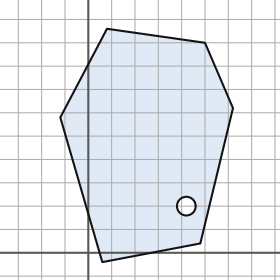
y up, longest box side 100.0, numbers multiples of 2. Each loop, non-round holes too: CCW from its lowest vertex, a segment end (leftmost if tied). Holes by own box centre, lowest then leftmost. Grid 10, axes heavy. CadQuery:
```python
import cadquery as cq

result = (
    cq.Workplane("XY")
    .moveTo(6.0, -4.0)
    .lineTo(48.0, 4.0)
    .lineTo(62.0, 62.0)
    .lineTo(50.0, 90.0)
    .lineTo(8.0, 96.0)
    .lineTo(-12.0, 58.0)
    .close()
    .moveTo(42.0, 20.0)
    .circle(4.0)
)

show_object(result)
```